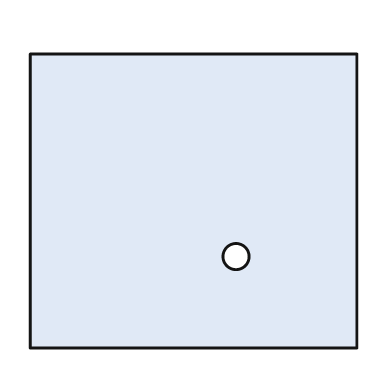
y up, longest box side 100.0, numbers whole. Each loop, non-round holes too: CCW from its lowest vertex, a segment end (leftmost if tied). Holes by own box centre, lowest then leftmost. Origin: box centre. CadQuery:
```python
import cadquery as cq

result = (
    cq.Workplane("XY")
    .moveTo(-50.0, -45.0)
    .lineTo(50.0, -45.0)
    .lineTo(50.0, 45.0)
    .lineTo(-50.0, 45.0)
    .close()
    .moveTo(13.0, -17.0)
    .circle(4.0)
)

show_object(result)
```